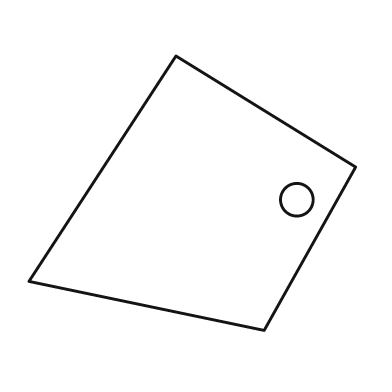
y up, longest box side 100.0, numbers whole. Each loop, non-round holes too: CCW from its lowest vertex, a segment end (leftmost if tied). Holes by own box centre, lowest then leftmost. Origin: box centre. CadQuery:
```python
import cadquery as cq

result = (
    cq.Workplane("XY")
    .moveTo(22.0, -42.0)
    .lineTo(50.0, 8.0)
    .lineTo(-5.0, 42.0)
    .lineTo(-50.0, -27.0)
    .close()
    .moveTo(32.0, -2.0)
    .circle(5.0)
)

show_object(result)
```